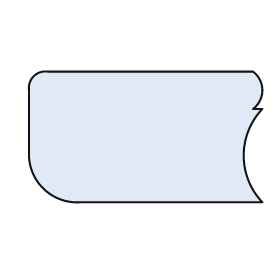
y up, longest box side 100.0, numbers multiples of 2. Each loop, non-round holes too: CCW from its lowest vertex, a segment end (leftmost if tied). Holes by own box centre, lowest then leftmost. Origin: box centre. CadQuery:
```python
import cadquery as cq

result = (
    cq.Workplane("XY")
    .moveTo(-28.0, -28.0)
    .lineTo(50.0, -28.0)
    .threePointArc((42.0, -8.0), (50.0, 12.0))
    .lineTo(46.0, 12.0)
    .threePointArc((50.0, 20.0), (46.0, 28.0))
    .lineTo(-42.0, 28.0)
    .threePointArc((-48.0, 26.0), (-50.0, 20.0))
    .lineTo(-50.0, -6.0)
    .threePointArc((-44.0, -22.0), (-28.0, -28.0))
    .close()
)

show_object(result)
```